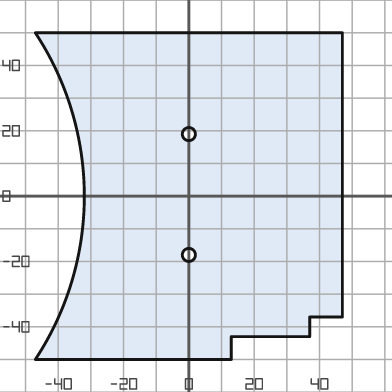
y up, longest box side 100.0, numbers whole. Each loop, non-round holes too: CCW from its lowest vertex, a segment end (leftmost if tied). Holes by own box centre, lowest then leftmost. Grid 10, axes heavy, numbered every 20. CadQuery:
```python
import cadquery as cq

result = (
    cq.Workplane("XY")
    .moveTo(-47.0, -50.0)
    .lineTo(13.0, -50.0)
    .lineTo(13.0, -43.0)
    .lineTo(37.0, -43.0)
    .lineTo(37.0, -37.0)
    .lineTo(47.0, -37.0)
    .lineTo(47.0, 50.0)
    .lineTo(-47.0, 50.0)
    .threePointArc((-32.0, 0.0), (-47.0, -50.0))
    .close()
    .moveTo(0.0, -18.0)
    .circle(2.0)
    .moveTo(0.0, 19.0)
    .circle(2.0)
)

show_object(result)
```